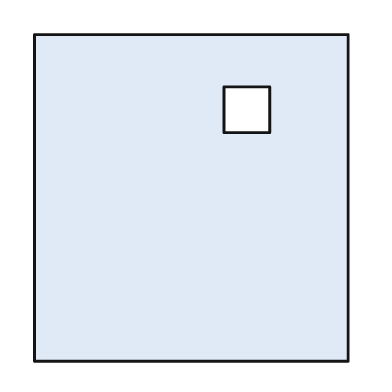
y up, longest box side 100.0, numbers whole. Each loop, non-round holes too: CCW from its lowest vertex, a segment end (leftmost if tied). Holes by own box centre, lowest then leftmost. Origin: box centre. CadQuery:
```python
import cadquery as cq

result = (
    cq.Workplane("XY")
    .moveTo(-48.0, -50.0)
    .lineTo(48.0, -50.0)
    .lineTo(48.0, 50.0)
    .lineTo(-48.0, 50.0)
    .close()
    .moveTo(10.0, 20.0)
    .lineTo(24.0, 20.0)
    .lineTo(24.0, 34.0)
    .lineTo(10.0, 34.0)
    .close()
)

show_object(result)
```